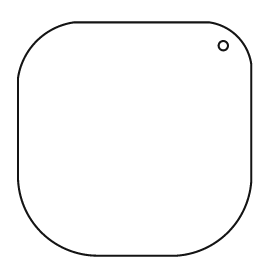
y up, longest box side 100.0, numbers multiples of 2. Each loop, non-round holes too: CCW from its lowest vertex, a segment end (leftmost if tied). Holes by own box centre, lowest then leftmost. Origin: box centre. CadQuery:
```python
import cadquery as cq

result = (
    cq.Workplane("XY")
    .moveTo(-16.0, -50.0)
    .lineTo(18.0, -50.0)
    .threePointArc((40.0, -40.0), (50.0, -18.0))
    .lineTo(50.0, 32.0)
    .threePointArc((44.0, 44.0), (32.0, 50.0))
    .lineTo(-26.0, 50.0)
    .threePointArc((-42.0, 42.0), (-50.0, 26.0))
    .lineTo(-50.0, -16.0)
    .threePointArc((-40.0, -40.0), (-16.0, -50.0))
    .close()
    .moveTo(38.0, 40.0)
    .circle(2.0)
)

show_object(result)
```